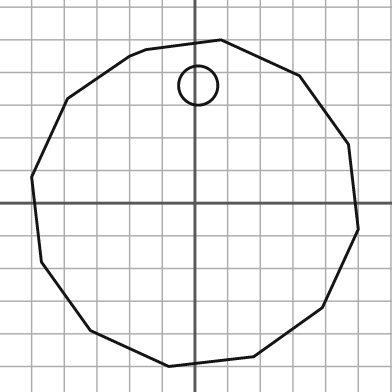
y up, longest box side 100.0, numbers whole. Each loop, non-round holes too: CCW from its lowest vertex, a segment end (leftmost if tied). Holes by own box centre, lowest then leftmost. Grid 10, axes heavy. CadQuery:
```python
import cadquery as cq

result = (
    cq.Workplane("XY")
    .moveTo(-8.0, -50.0)
    .lineTo(18.0, -47.0)
    .lineTo(39.0, -32.0)
    .lineTo(50.0, -8.0)
    .lineTo(47.0, 18.0)
    .lineTo(32.0, 39.0)
    .lineTo(8.0, 50.0)
    .lineTo(-15.0, 47.0)
    .lineTo(-20.0, 45.0)
    .lineTo(-39.0, 32.0)
    .lineTo(-50.0, 8.0)
    .lineTo(-47.0, -18.0)
    .lineTo(-32.0, -39.0)
    .close()
    .moveTo(1.0, 36.0)
    .circle(6.0)
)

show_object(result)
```